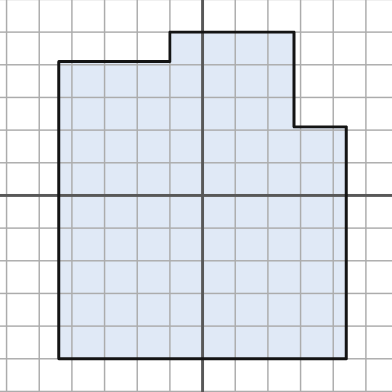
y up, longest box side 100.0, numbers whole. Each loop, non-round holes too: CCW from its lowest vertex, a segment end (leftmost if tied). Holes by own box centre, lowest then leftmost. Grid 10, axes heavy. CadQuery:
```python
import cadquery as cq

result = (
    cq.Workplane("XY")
    .moveTo(-44.0, -50.0)
    .lineTo(44.0, -50.0)
    .lineTo(44.0, 21.0)
    .lineTo(28.0, 21.0)
    .lineTo(28.0, 50.0)
    .lineTo(-10.0, 50.0)
    .lineTo(-10.0, 41.0)
    .lineTo(-44.0, 41.0)
    .close()
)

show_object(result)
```